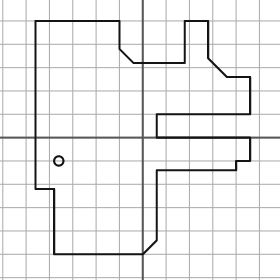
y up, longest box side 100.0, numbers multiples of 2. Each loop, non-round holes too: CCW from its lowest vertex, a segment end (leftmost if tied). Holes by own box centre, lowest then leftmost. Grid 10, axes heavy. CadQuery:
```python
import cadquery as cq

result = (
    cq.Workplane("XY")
    .moveTo(-38.0, -50.0)
    .lineTo(0.0, -50.0)
    .lineTo(6.0, -44.0)
    .lineTo(6.0, -14.0)
    .lineTo(40.0, -14.0)
    .lineTo(40.0, -10.0)
    .lineTo(46.0, -10.0)
    .lineTo(46.0, 0.0)
    .lineTo(6.0, 0.0)
    .lineTo(6.0, 10.0)
    .lineTo(46.0, 10.0)
    .lineTo(46.0, 26.0)
    .lineTo(36.0, 26.0)
    .lineTo(28.0, 34.0)
    .lineTo(28.0, 50.0)
    .lineTo(18.0, 50.0)
    .lineTo(18.0, 32.0)
    .lineTo(-4.0, 32.0)
    .lineTo(-10.0, 38.0)
    .lineTo(-10.0, 50.0)
    .lineTo(-46.0, 50.0)
    .lineTo(-46.0, -22.0)
    .lineTo(-38.0, -22.0)
    .close()
    .moveTo(-36.0, -10.0)
    .circle(2.0)
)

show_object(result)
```